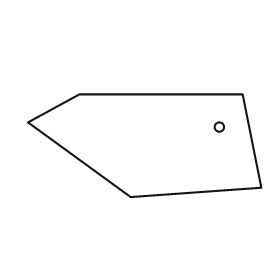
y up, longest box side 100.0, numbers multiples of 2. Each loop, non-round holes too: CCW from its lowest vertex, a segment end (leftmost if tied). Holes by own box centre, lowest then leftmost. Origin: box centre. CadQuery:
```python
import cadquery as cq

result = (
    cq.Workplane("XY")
    .moveTo(-6.0, -22.0)
    .lineTo(50.0, -18.0)
    .lineTo(42.0, 22.0)
    .lineTo(-28.0, 22.0)
    .lineTo(-50.0, 10.0)
    .close()
    .moveTo(32.0, 8.0)
    .circle(2.0)
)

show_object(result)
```